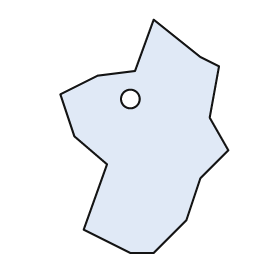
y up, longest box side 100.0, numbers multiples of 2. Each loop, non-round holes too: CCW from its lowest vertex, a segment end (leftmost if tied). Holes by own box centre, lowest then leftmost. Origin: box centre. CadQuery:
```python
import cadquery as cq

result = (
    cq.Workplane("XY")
    .moveTo(-6.0, -50.0)
    .lineTo(4.0, -50.0)
    .lineTo(18.0, -36.0)
    .lineTo(24.0, -18.0)
    .lineTo(36.0, -6.0)
    .lineTo(28.0, 8.0)
    .lineTo(32.0, 30.0)
    .lineTo(24.0, 34.0)
    .lineTo(4.0, 50.0)
    .lineTo(-4.0, 28.0)
    .lineTo(-20.0, 26.0)
    .lineTo(-36.0, 18.0)
    .lineTo(-30.0, 0.0)
    .lineTo(-16.0, -12.0)
    .lineTo(-26.0, -40.0)
    .close()
    .moveTo(-6.0, 16.0)
    .circle(4.0)
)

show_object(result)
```